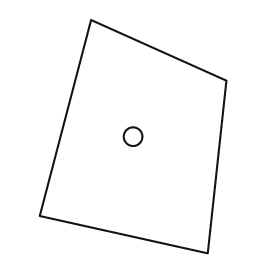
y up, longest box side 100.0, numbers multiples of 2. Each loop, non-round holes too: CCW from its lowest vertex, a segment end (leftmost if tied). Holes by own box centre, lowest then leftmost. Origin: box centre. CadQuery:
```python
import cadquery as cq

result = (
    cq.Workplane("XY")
    .moveTo(32.0, -50.0)
    .lineTo(40.0, 24.0)
    .lineTo(-18.0, 50.0)
    .lineTo(-40.0, -34.0)
    .close()
    .moveTo(0.0, 0.0)
    .circle(4.0)
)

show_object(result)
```